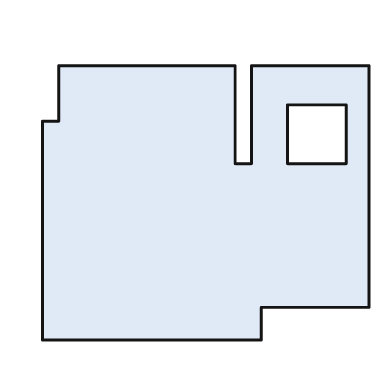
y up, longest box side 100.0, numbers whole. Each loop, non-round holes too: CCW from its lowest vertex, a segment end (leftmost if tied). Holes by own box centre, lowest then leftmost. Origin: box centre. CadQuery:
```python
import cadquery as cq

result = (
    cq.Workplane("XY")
    .moveTo(-50.0, -42.0)
    .lineTo(17.0, -42.0)
    .lineTo(17.0, -32.0)
    .lineTo(50.0, -32.0)
    .lineTo(50.0, 42.0)
    .lineTo(14.0, 42.0)
    .lineTo(14.0, 12.0)
    .lineTo(9.0, 12.0)
    .lineTo(9.0, 42.0)
    .lineTo(-45.0, 42.0)
    .lineTo(-45.0, 25.0)
    .lineTo(-50.0, 25.0)
    .close()
    .moveTo(25.0, 12.0)
    .lineTo(43.0, 12.0)
    .lineTo(43.0, 30.0)
    .lineTo(25.0, 30.0)
    .close()
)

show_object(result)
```